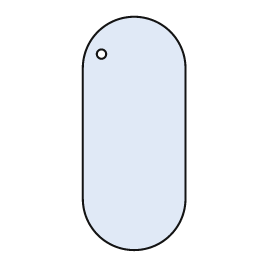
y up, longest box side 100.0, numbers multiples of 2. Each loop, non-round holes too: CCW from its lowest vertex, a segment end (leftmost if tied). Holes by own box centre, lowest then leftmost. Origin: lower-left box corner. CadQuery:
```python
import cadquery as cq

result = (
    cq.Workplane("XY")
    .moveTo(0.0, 22.0)
    .threePointArc((22.0, 0.0), (44.0, 22.0))
    .lineTo(44.0, 78.0)
    .threePointArc((22.0, 100.0), (0.0, 78.0))
    .close()
    .moveTo(8.0, 84.0)
    .circle(2.0)
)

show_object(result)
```